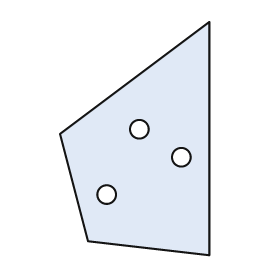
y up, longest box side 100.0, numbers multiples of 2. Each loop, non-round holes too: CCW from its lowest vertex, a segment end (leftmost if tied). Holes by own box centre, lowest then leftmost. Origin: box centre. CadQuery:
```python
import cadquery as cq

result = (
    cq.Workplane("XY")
    .moveTo(32.0, -50.0)
    .lineTo(32.0, 50.0)
    .lineTo(-32.0, 2.0)
    .lineTo(-20.0, -44.0)
    .close()
    .moveTo(-12.0, -24.0)
    .circle(4.0)
    .moveTo(20.0, -8.0)
    .circle(4.0)
    .moveTo(2.0, 4.0)
    .circle(4.0)
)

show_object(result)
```